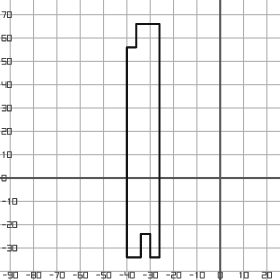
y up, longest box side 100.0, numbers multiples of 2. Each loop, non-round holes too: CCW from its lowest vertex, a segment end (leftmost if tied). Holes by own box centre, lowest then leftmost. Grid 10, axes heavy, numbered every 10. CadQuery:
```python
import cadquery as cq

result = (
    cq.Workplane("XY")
    .moveTo(-40.0, -34.0)
    .lineTo(-34.0, -34.0)
    .lineTo(-34.0, -24.0)
    .lineTo(-30.0, -24.0)
    .lineTo(-30.0, -34.0)
    .lineTo(-26.0, -34.0)
    .lineTo(-26.0, 66.0)
    .lineTo(-36.0, 66.0)
    .lineTo(-36.0, 56.0)
    .lineTo(-40.0, 56.0)
    .close()
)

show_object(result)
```